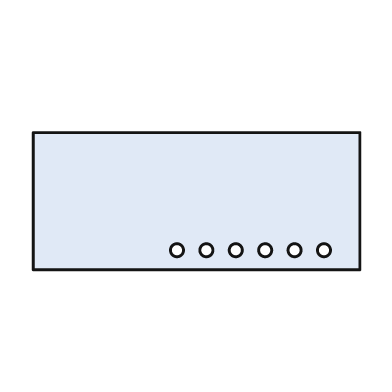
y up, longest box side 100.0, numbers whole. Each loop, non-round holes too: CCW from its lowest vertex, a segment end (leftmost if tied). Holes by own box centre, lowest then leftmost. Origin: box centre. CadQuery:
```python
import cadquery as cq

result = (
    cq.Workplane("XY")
    .moveTo(-50.0, -21.0)
    .lineTo(50.0, -21.0)
    .lineTo(50.0, 21.0)
    .lineTo(-50.0, 21.0)
    .close()
    .moveTo(-6.0, -15.0)
    .circle(2.0)
    .moveTo(3.0, -15.0)
    .circle(2.0)
    .moveTo(12.0, -15.0)
    .circle(2.0)
    .moveTo(21.0, -15.0)
    .circle(2.0)
    .moveTo(30.0, -15.0)
    .circle(2.0)
    .moveTo(39.0, -15.0)
    .circle(2.0)
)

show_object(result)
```